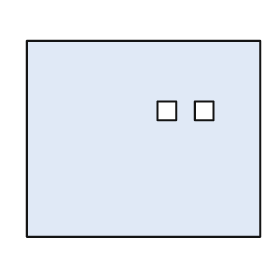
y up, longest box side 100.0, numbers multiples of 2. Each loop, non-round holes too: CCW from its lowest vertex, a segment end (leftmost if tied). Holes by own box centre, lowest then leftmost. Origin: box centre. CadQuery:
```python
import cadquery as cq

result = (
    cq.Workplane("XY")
    .moveTo(-50.0, -42.0)
    .lineTo(50.0, -42.0)
    .lineTo(50.0, 42.0)
    .lineTo(-50.0, 42.0)
    .close()
    .moveTo(6.0, 8.0)
    .lineTo(14.0, 8.0)
    .lineTo(14.0, 16.0)
    .lineTo(6.0, 16.0)
    .close()
    .moveTo(22.0, 8.0)
    .lineTo(30.0, 8.0)
    .lineTo(30.0, 16.0)
    .lineTo(22.0, 16.0)
    .close()
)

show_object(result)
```